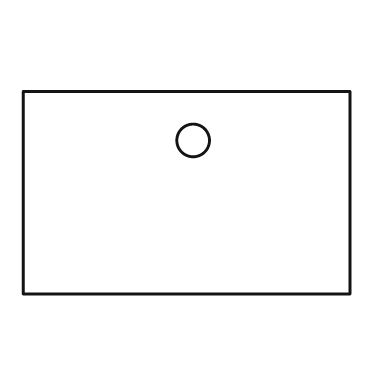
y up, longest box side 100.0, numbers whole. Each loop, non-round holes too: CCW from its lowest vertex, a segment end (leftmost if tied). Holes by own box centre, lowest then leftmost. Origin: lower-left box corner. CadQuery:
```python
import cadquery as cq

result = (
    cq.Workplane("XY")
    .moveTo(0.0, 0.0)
    .lineTo(100.0, 0.0)
    .lineTo(100.0, 62.0)
    .lineTo(0.0, 62.0)
    .close()
    .moveTo(52.0, 47.0)
    .circle(5.0)
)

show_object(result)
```